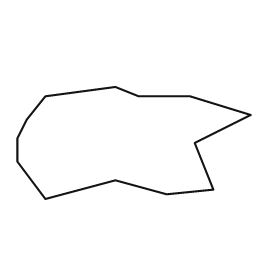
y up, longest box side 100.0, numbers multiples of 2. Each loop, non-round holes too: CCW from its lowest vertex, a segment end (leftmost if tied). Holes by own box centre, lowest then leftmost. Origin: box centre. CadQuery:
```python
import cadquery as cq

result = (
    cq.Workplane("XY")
    .moveTo(-38.0, -24.0)
    .lineTo(-8.0, -16.0)
    .lineTo(14.0, -22.0)
    .lineTo(34.0, -20.0)
    .lineTo(26.0, 0.0)
    .lineTo(50.0, 12.0)
    .lineTo(24.0, 20.0)
    .lineTo(2.0, 20.0)
    .lineTo(-8.0, 24.0)
    .lineTo(-38.0, 20.0)
    .lineTo(-46.0, 10.0)
    .lineTo(-50.0, 2.0)
    .lineTo(-50.0, -8.0)
    .close()
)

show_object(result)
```